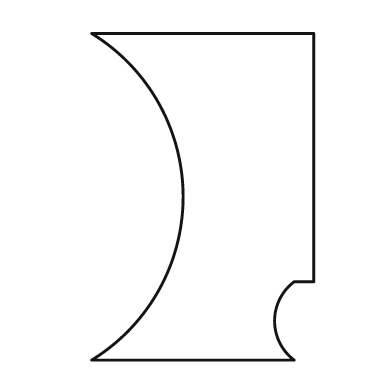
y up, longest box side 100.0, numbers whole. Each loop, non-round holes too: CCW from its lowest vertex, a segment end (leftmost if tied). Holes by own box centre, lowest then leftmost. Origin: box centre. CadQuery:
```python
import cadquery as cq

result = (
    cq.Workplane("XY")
    .moveTo(-34.0, -50.0)
    .lineTo(28.0, -50.0)
    .threePointArc((22.0, -38.0), (28.0, -26.0))
    .lineTo(34.0, -26.0)
    .lineTo(34.0, 50.0)
    .lineTo(-34.0, 50.0)
    .threePointArc((-6.0, 0.0), (-34.0, -50.0))
    .close()
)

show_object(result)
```